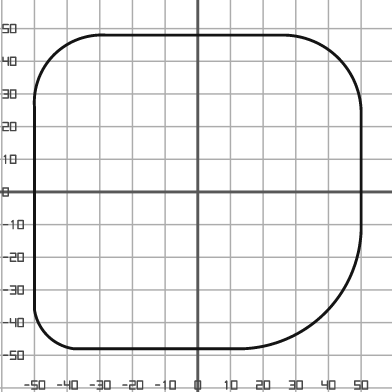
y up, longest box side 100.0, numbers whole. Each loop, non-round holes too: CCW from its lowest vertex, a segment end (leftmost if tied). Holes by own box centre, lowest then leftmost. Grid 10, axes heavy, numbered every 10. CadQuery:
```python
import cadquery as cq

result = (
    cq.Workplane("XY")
    .moveTo(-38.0, -48.0)
    .lineTo(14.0, -48.0)
    .threePointArc((39.0, -37.0), (50.0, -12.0))
    .lineTo(50.0, 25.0)
    .threePointArc((43.0, 41.0), (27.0, 48.0))
    .lineTo(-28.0, 48.0)
    .threePointArc((-44.0, 42.0), (-50.0, 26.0))
    .lineTo(-50.0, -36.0)
    .threePointArc((-46.0, -44.0), (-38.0, -48.0))
    .close()
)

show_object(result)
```